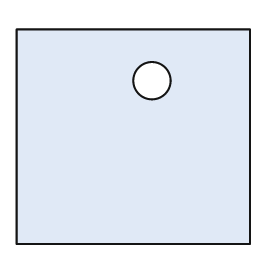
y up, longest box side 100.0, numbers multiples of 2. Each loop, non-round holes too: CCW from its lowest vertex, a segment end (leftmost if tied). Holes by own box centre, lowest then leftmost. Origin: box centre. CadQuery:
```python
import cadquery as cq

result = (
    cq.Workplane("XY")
    .moveTo(-50.0, -46.0)
    .lineTo(50.0, -46.0)
    .lineTo(50.0, 46.0)
    .lineTo(-50.0, 46.0)
    .close()
    .moveTo(8.0, 24.0)
    .circle(8.0)
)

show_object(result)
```